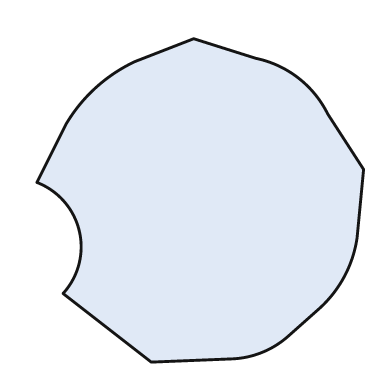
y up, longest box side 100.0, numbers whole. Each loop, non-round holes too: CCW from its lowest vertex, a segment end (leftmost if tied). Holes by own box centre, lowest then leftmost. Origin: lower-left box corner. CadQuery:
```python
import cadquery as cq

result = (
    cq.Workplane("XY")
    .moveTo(35.0, 0.0)
    .lineTo(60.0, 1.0)
    .threePointArc((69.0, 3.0), (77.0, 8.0))
    .lineTo(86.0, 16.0)
    .threePointArc((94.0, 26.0), (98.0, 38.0))
    .lineTo(100.0, 59.0)
    .lineTo(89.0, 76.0)
    .threePointArc((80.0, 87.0), (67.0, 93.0))
    .lineTo(48.0, 99.0)
    .lineTo(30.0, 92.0)
    .threePointArc((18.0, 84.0), (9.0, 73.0))
    .lineTo(0.0, 55.0)
    .threePointArc((13.0, 40.0), (8.0, 21.0))
    .close()
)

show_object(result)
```